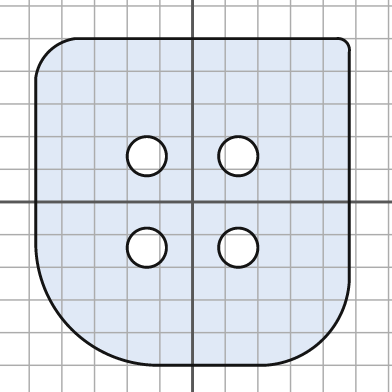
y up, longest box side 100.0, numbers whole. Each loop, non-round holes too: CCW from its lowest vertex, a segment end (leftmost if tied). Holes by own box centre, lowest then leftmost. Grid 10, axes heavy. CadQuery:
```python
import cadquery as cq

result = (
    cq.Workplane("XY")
    .moveTo(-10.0, -50.0)
    .lineTo(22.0, -50.0)
    .threePointArc((40.0, -42.0), (48.0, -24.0))
    .lineTo(48.0, 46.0)
    .threePointArc((47.0, 49.0), (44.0, 50.0))
    .lineTo(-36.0, 50.0)
    .threePointArc((-44.0, 46.0), (-48.0, 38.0))
    .lineTo(-48.0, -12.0)
    .threePointArc((-37.0, -39.0), (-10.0, -50.0))
    .close()
    .moveTo(-14.0, -14.0)
    .circle(6.0)
    .moveTo(14.0, -14.0)
    .circle(6.0)
    .moveTo(-14.0, 14.0)
    .circle(6.0)
    .moveTo(14.0, 14.0)
    .circle(6.0)
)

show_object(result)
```